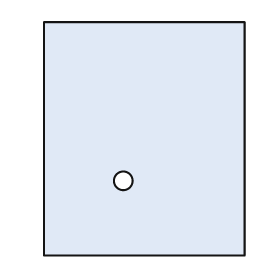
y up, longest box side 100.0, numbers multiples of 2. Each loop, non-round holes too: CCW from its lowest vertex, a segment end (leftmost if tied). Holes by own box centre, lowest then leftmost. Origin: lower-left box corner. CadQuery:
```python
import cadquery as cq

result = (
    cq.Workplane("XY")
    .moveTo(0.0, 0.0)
    .lineTo(86.0, 0.0)
    .lineTo(86.0, 100.0)
    .lineTo(0.0, 100.0)
    .close()
    .moveTo(34.0, 32.0)
    .circle(4.0)
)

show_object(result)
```